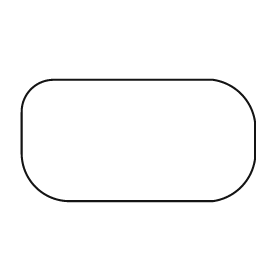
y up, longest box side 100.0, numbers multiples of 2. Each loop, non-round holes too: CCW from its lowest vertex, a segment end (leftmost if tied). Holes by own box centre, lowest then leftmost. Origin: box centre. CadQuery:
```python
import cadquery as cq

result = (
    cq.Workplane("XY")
    .moveTo(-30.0, -26.0)
    .lineTo(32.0, -26.0)
    .threePointArc((44.0, -20.0), (50.0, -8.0))
    .lineTo(50.0, 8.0)
    .threePointArc((44.0, 20.0), (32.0, 26.0))
    .lineTo(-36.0, 26.0)
    .threePointArc((-46.0, 22.0), (-50.0, 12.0))
    .lineTo(-50.0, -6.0)
    .threePointArc((-44.0, -20.0), (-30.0, -26.0))
    .close()
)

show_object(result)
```